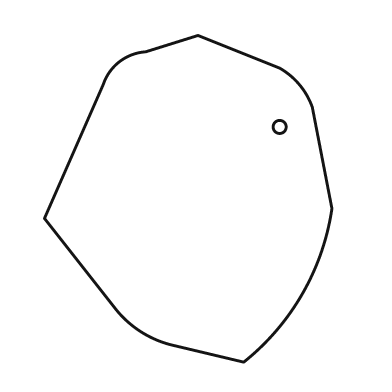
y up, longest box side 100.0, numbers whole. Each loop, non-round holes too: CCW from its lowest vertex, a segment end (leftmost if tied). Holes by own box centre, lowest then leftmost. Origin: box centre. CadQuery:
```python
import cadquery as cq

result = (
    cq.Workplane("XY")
    .moveTo(17.0, -50.0)
    .threePointArc((35.0, -29.0), (44.0, -3.0))
    .lineTo(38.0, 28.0)
    .threePointArc((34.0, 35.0), (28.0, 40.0))
    .lineTo(3.0, 50.0)
    .lineTo(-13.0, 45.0)
    .threePointArc((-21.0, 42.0), (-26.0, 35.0))
    .lineTo(-44.0, -6.0)
    .lineTo(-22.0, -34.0)
    .threePointArc((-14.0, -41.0), (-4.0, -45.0))
    .close()
    .moveTo(28.0, 22.0)
    .circle(2.0)
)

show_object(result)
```